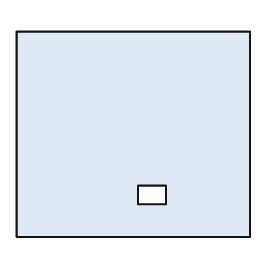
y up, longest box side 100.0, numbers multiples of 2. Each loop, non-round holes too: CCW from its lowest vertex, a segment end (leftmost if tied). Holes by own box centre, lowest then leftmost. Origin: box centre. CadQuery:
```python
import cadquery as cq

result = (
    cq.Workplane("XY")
    .moveTo(-50.0, -44.0)
    .lineTo(50.0, -44.0)
    .lineTo(50.0, 44.0)
    .lineTo(-50.0, 44.0)
    .close()
    .moveTo(2.0, -30.0)
    .lineTo(14.0, -30.0)
    .lineTo(14.0, -22.0)
    .lineTo(2.0, -22.0)
    .close()
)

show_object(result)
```